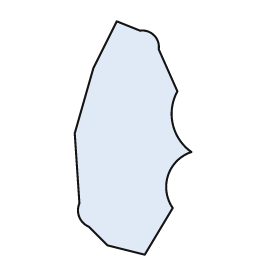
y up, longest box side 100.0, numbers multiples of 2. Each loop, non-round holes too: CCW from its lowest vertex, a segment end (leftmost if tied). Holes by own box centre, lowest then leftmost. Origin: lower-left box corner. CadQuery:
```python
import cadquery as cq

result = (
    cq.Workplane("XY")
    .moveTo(30.0, 0.0)
    .lineTo(42.0, 20.0)
    .threePointArc((40.0, 34.0), (50.0, 44.0))
    .threePointArc((42.0, 56.0), (44.0, 70.0))
    .lineTo(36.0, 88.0)
    .threePointArc((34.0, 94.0), (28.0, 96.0))
    .lineTo(18.0, 100.0)
    .lineTo(8.0, 80.0)
    .lineTo(0.0, 52.0)
    .lineTo(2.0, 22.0)
    .threePointArc((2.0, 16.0), (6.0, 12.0))
    .lineTo(14.0, 4.0)
    .close()
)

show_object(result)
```